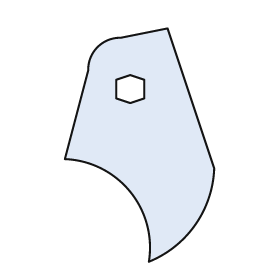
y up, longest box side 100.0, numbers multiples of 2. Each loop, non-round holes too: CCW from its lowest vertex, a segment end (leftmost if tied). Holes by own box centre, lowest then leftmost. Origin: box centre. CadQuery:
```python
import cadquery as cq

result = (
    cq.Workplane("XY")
    .moveTo(4.0, -50.0)
    .threePointArc((24.0, -34.0), (32.0, -10.0))
    .lineTo(12.0, 50.0)
    .lineTo(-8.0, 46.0)
    .threePointArc((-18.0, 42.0), (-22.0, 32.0))
    .lineTo(-32.0, -6.0)
    .threePointArc((-4.0, -20.0), (4.0, -50.0))
    .close()
    .moveTo(-4.0, 18.0)
    .lineTo(2.0, 20.0)
    .lineTo(2.0, 28.0)
    .lineTo(-4.0, 30.0)
    .lineTo(-10.0, 28.0)
    .lineTo(-10.0, 20.0)
    .close()
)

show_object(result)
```